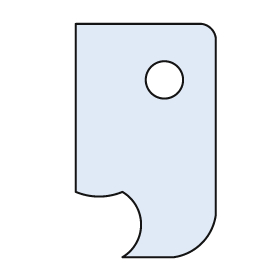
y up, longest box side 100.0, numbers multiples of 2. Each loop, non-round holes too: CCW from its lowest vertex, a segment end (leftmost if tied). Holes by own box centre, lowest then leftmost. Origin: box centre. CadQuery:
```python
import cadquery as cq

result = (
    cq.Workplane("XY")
    .moveTo(-10.0, -50.0)
    .lineTo(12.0, -50.0)
    .threePointArc((24.0, -44.0), (30.0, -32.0))
    .lineTo(30.0, 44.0)
    .threePointArc((28.0, 48.0), (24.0, 50.0))
    .lineTo(-30.0, 50.0)
    .lineTo(-30.0, -22.0)
    .threePointArc((-20.0, -24.0), (-10.0, -22.0))
    .threePointArc((-2.0, -36.0), (-10.0, -50.0))
    .close()
    .moveTo(8.0, 26.0)
    .circle(8.0)
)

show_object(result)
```